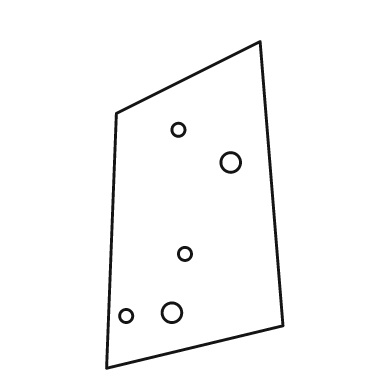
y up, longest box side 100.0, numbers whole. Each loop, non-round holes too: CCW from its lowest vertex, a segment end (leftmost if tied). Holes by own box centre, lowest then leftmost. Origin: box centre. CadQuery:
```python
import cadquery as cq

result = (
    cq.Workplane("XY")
    .moveTo(-27.0, -50.0)
    .lineTo(27.0, -37.0)
    .lineTo(20.0, 50.0)
    .lineTo(-24.0, 28.0)
    .close()
    .moveTo(-21.0, -34.0)
    .circle(2.0)
    .moveTo(-7.0, -33.0)
    .circle(3.0)
    .moveTo(-3.0, -15.0)
    .circle(2.0)
    .moveTo(11.0, 13.0)
    .circle(3.0)
    .moveTo(-5.0, 23.0)
    .circle(2.0)
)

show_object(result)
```